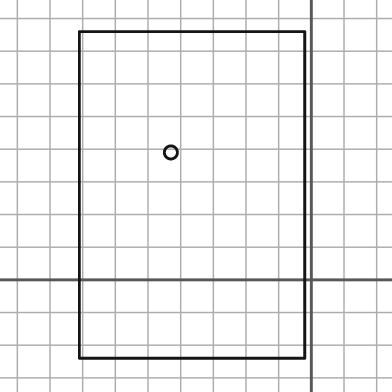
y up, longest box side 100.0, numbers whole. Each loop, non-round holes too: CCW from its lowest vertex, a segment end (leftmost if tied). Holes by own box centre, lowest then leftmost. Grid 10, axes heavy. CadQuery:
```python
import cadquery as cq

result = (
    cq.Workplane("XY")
    .moveTo(-71.0, -24.0)
    .lineTo(-2.0, -24.0)
    .lineTo(-2.0, 76.0)
    .lineTo(-71.0, 76.0)
    .close()
    .moveTo(-43.0, 39.0)
    .circle(2.0)
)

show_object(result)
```